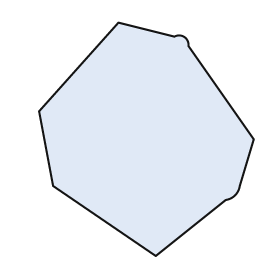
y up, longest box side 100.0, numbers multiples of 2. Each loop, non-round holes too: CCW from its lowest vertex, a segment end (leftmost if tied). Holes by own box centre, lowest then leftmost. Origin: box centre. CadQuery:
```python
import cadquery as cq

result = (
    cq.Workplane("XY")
    .moveTo(4.0, -50.0)
    .lineTo(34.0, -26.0)
    .threePointArc((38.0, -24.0), (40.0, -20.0))
    .lineTo(46.0, 0.0)
    .lineTo(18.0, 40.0)
    .threePointArc((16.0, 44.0), (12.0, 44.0))
    .lineTo(-12.0, 50.0)
    .lineTo(-46.0, 12.0)
    .lineTo(-40.0, -20.0)
    .close()
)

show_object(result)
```